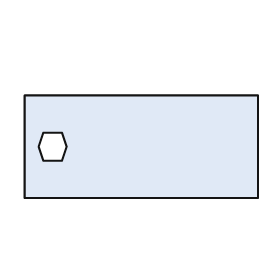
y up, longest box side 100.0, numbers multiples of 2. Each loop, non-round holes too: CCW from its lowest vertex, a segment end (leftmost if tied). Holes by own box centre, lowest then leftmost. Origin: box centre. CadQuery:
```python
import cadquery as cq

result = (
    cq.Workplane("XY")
    .moveTo(-50.0, -22.0)
    .lineTo(50.0, -22.0)
    .lineTo(50.0, 22.0)
    .lineTo(-50.0, 22.0)
    .close()
    .moveTo(-42.0, -6.0)
    .lineTo(-34.0, -6.0)
    .lineTo(-32.0, 0.0)
    .lineTo(-34.0, 6.0)
    .lineTo(-42.0, 6.0)
    .lineTo(-44.0, 0.0)
    .close()
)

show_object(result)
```